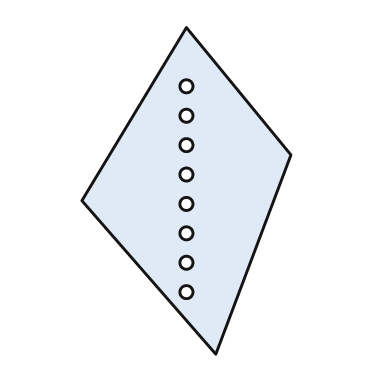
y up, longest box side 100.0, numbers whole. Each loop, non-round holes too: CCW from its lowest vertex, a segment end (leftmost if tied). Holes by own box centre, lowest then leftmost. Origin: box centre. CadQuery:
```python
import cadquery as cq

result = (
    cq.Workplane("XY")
    .moveTo(9.0, -50.0)
    .lineTo(32.0, 11.0)
    .lineTo(0.0, 50.0)
    .lineTo(-32.0, -3.0)
    .close()
    .moveTo(0.0, -31.0)
    .circle(2.0)
    .moveTo(0.0, -22.0)
    .circle(2.0)
    .moveTo(0.0, -13.0)
    .circle(2.0)
    .moveTo(0.0, -4.0)
    .circle(2.0)
    .moveTo(0.0, 5.0)
    .circle(2.0)
    .moveTo(0.0, 14.0)
    .circle(2.0)
    .moveTo(0.0, 23.0)
    .circle(2.0)
    .moveTo(0.0, 32.0)
    .circle(2.0)
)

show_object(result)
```